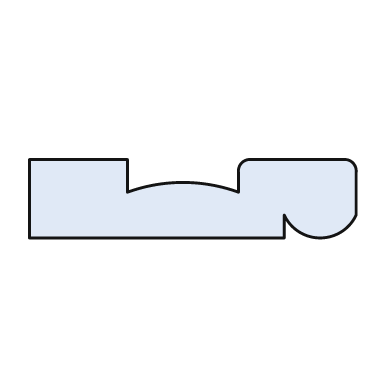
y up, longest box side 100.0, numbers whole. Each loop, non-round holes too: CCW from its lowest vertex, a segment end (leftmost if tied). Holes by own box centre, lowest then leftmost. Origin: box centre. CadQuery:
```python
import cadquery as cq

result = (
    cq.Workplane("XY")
    .moveTo(-50.0, -12.0)
    .lineTo(28.0, -12.0)
    .lineTo(28.0, -5.0)
    .threePointArc((39.0, -12.0), (50.0, -5.0))
    .lineTo(50.0, 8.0)
    .threePointArc((49.0, 11.0), (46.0, 12.0))
    .lineTo(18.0, 12.0)
    .threePointArc((15.0, 11.0), (14.0, 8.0))
    .lineTo(14.0, 2.0)
    .threePointArc((-3.0, 5.0), (-20.0, 2.0))
    .lineTo(-20.0, 12.0)
    .lineTo(-50.0, 12.0)
    .close()
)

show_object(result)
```